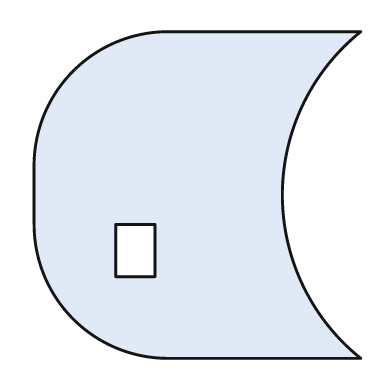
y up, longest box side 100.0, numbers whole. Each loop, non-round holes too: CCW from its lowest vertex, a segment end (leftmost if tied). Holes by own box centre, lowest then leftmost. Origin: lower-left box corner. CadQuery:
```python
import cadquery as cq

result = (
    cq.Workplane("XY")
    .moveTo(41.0, 0.0)
    .lineTo(100.0, 0.0)
    .threePointArc((76.0, 50.0), (100.0, 100.0))
    .lineTo(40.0, 100.0)
    .threePointArc((12.0, 88.0), (0.0, 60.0))
    .lineTo(0.0, 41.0)
    .threePointArc((12.0, 12.0), (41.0, 0.0))
    .close()
    .moveTo(25.0, 25.0)
    .lineTo(37.0, 25.0)
    .lineTo(37.0, 41.0)
    .lineTo(25.0, 41.0)
    .close()
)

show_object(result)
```